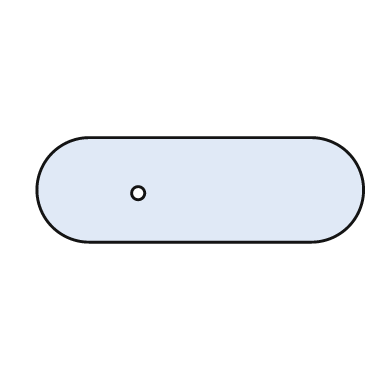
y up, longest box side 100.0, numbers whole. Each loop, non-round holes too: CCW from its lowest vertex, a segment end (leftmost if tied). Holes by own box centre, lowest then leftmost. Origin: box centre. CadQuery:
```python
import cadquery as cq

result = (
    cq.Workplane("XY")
    .moveTo(-34.0, -16.0)
    .lineTo(34.0, -16.0)
    .threePointArc((50.0, 0.0), (34.0, 16.0))
    .lineTo(-34.0, 16.0)
    .threePointArc((-50.0, 0.0), (-34.0, -16.0))
    .close()
    .moveTo(-19.0, -1.0)
    .circle(2.0)
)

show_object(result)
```